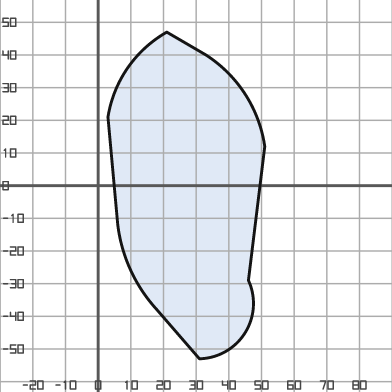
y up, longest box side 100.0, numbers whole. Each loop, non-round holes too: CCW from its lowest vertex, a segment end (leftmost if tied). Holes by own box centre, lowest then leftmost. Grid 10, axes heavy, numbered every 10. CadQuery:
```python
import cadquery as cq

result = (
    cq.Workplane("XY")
    .moveTo(31.0, -53.0)
    .threePointArc((45.0, -45.0), (46.0, -29.0))
    .lineTo(51.0, 12.0)
    .threePointArc((45.0, 28.0), (33.0, 40.0))
    .lineTo(21.0, 47.0)
    .threePointArc((9.0, 36.0), (3.0, 21.0))
    .lineTo(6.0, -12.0)
    .threePointArc((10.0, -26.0), (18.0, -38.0))
    .close()
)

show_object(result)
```